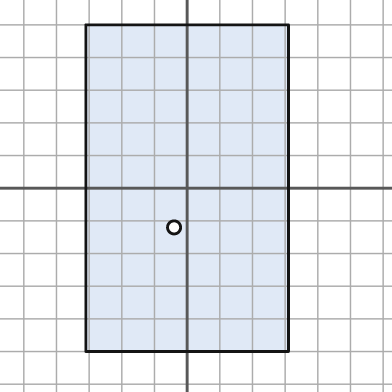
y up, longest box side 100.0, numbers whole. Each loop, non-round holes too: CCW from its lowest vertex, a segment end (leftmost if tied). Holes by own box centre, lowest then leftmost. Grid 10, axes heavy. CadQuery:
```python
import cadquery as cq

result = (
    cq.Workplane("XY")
    .moveTo(-31.0, -50.0)
    .lineTo(31.0, -50.0)
    .lineTo(31.0, 50.0)
    .lineTo(-31.0, 50.0)
    .close()
    .moveTo(-4.0, -12.0)
    .circle(2.0)
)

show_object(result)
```